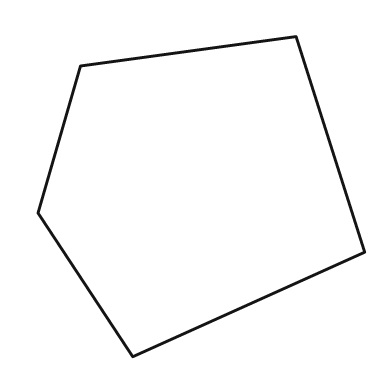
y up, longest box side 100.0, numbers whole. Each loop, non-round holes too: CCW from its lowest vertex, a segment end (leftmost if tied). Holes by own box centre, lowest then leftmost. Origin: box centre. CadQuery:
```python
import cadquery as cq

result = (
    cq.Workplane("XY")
    .moveTo(-21.0, -49.0)
    .lineTo(50.0, -17.0)
    .lineTo(29.0, 49.0)
    .lineTo(-37.0, 40.0)
    .lineTo(-50.0, -5.0)
    .close()
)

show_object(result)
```